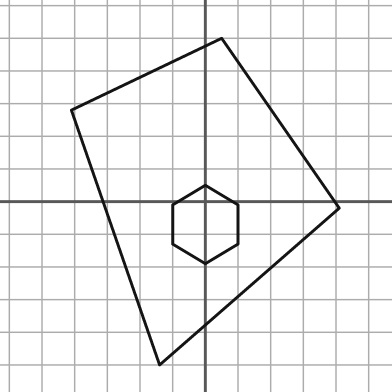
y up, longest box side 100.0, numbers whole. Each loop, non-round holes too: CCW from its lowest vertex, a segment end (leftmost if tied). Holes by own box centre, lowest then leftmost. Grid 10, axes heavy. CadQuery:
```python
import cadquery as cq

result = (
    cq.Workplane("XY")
    .moveTo(-14.0, -50.0)
    .lineTo(41.0, -2.0)
    .lineTo(5.0, 50.0)
    .lineTo(-41.0, 28.0)
    .close()
    .moveTo(0.0, -19.0)
    .lineTo(10.0, -13.0)
    .lineTo(10.0, -1.0)
    .lineTo(0.0, 5.0)
    .lineTo(-10.0, -1.0)
    .lineTo(-10.0, -13.0)
    .close()
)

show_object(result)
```